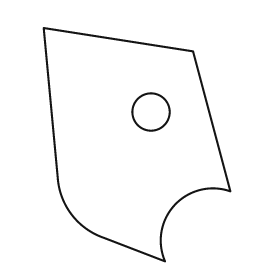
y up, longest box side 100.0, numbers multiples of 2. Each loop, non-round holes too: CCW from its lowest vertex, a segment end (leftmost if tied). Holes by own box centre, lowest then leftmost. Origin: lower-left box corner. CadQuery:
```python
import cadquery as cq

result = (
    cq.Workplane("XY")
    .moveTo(52.0, 0.0)
    .threePointArc((56.0, 24.0), (80.0, 30.0))
    .lineTo(64.0, 90.0)
    .lineTo(0.0, 100.0)
    .lineTo(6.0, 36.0)
    .threePointArc((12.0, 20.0), (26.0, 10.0))
    .close()
    .moveTo(46.0, 64.0)
    .circle(8.0)
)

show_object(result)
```